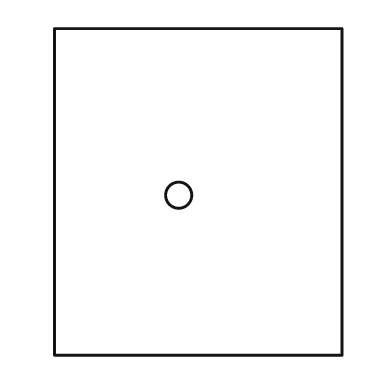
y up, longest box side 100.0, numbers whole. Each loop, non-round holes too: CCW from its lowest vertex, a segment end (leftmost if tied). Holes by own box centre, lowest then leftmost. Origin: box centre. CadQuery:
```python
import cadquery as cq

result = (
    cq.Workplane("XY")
    .moveTo(-44.0, -50.0)
    .lineTo(44.0, -50.0)
    .lineTo(44.0, 50.0)
    .lineTo(-44.0, 50.0)
    .close()
    .moveTo(-6.0, -1.0)
    .circle(4.0)
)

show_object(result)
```